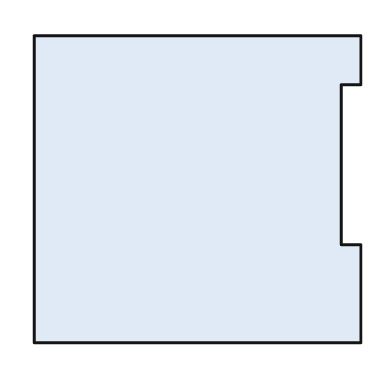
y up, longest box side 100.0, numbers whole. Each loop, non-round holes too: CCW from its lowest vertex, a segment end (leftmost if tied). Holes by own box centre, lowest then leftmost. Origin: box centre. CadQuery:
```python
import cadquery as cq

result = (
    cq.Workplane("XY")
    .moveTo(-50.0, -47.0)
    .lineTo(50.0, -47.0)
    .lineTo(50.0, -17.0)
    .lineTo(44.0, -17.0)
    .lineTo(44.0, 32.0)
    .lineTo(50.0, 32.0)
    .lineTo(50.0, 47.0)
    .lineTo(-50.0, 47.0)
    .close()
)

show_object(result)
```